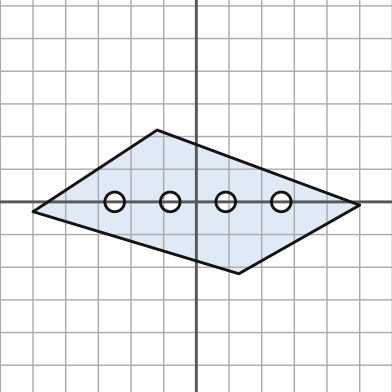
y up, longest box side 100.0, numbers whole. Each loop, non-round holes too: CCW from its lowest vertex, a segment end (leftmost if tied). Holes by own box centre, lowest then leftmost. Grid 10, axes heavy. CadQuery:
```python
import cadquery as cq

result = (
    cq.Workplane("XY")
    .moveTo(13.0, -22.0)
    .lineTo(50.0, -1.0)
    .lineTo(-12.0, 22.0)
    .lineTo(-50.0, -3.0)
    .close()
    .moveTo(-25.0, 0.0)
    .circle(3.0)
    .moveTo(-8.0, 0.0)
    .circle(3.0)
    .moveTo(9.0, 0.0)
    .circle(3.0)
    .moveTo(26.0, 0.0)
    .circle(3.0)
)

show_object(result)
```